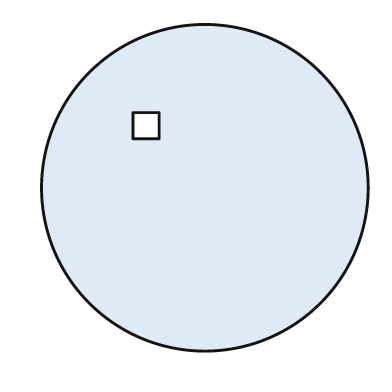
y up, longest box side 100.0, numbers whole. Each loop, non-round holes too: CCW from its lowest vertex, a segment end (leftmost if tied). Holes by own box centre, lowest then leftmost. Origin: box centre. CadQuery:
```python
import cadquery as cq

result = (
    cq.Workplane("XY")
    .moveTo(0.0, 0.0)
    .circle(50.0)
    .moveTo(-22.0, 15.0)
    .lineTo(-14.0, 15.0)
    .lineTo(-14.0, 23.0)
    .lineTo(-22.0, 23.0)
    .close()
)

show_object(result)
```